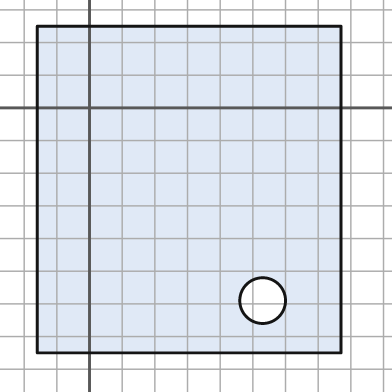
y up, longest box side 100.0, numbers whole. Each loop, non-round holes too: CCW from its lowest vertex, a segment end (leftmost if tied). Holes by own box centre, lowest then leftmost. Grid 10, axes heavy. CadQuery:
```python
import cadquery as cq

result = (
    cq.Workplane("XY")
    .moveTo(-16.0, -75.0)
    .lineTo(77.0, -75.0)
    .lineTo(77.0, 25.0)
    .lineTo(-16.0, 25.0)
    .close()
    .moveTo(53.0, -59.0)
    .circle(7.0)
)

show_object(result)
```